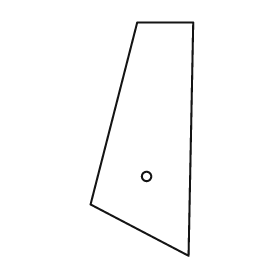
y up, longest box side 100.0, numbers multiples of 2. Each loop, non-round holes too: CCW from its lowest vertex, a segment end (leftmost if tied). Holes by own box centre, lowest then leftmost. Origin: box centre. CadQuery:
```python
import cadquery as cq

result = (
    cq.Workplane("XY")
    .moveTo(20.0, -50.0)
    .lineTo(22.0, 50.0)
    .lineTo(-2.0, 50.0)
    .lineTo(-22.0, -28.0)
    .close()
    .moveTo(2.0, -16.0)
    .circle(2.0)
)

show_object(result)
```